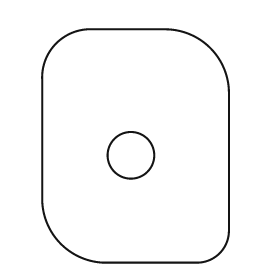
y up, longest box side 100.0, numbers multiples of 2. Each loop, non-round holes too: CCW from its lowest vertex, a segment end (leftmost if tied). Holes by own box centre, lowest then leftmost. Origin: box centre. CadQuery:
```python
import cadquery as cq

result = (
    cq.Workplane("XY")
    .moveTo(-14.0, -50.0)
    .lineTo(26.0, -50.0)
    .threePointArc((36.0, -46.0), (40.0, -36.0))
    .lineTo(40.0, 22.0)
    .threePointArc((32.0, 42.0), (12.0, 50.0))
    .lineTo(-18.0, 50.0)
    .threePointArc((-34.0, 44.0), (-40.0, 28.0))
    .lineTo(-40.0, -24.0)
    .threePointArc((-32.0, -42.0), (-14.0, -50.0))
    .close()
    .moveTo(-2.0, -4.0)
    .circle(10.0)
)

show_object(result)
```